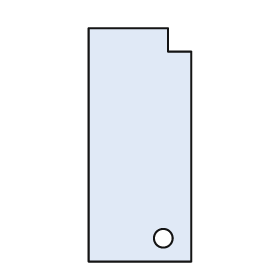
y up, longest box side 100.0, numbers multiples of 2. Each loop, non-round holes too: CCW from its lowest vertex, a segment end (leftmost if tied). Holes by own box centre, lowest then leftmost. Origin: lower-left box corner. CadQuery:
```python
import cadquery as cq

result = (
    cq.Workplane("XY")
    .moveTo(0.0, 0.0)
    .lineTo(44.0, 0.0)
    .lineTo(44.0, 90.0)
    .lineTo(34.0, 90.0)
    .lineTo(34.0, 100.0)
    .lineTo(0.0, 100.0)
    .close()
    .moveTo(32.0, 10.0)
    .circle(4.0)
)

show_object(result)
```